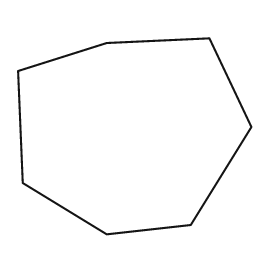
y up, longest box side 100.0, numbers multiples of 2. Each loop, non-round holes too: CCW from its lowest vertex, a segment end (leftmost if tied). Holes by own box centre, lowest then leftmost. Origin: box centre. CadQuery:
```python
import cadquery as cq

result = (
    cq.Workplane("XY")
    .moveTo(-12.0, -42.0)
    .lineTo(24.0, -38.0)
    .lineTo(50.0, 4.0)
    .lineTo(32.0, 42.0)
    .lineTo(-12.0, 40.0)
    .lineTo(-50.0, 28.0)
    .lineTo(-48.0, -20.0)
    .close()
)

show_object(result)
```